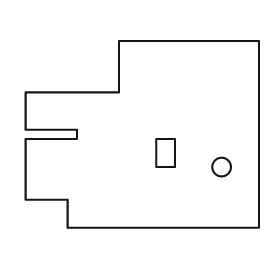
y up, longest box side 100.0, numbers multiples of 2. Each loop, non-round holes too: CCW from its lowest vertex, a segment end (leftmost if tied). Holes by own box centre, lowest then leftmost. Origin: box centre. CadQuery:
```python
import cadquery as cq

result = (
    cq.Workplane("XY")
    .moveTo(-32.0, -40.0)
    .lineTo(50.0, -40.0)
    .lineTo(50.0, 40.0)
    .lineTo(-10.0, 40.0)
    .lineTo(-10.0, 18.0)
    .lineTo(-50.0, 18.0)
    .lineTo(-50.0, 2.0)
    .lineTo(-28.0, 2.0)
    .lineTo(-28.0, -2.0)
    .lineTo(-50.0, -2.0)
    .lineTo(-50.0, -28.0)
    .lineTo(-32.0, -28.0)
    .close()
    .moveTo(34.0, -14.0)
    .circle(4.0)
    .moveTo(6.0, -14.0)
    .lineTo(14.0, -14.0)
    .lineTo(14.0, -2.0)
    .lineTo(6.0, -2.0)
    .close()
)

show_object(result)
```